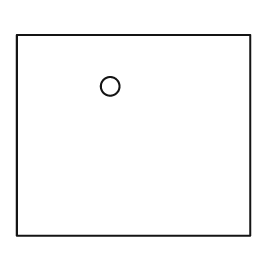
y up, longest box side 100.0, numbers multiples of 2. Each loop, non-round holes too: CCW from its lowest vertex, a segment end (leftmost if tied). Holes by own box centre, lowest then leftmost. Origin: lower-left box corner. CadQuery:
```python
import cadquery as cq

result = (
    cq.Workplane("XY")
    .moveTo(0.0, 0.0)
    .lineTo(100.0, 0.0)
    .lineTo(100.0, 86.0)
    .lineTo(0.0, 86.0)
    .close()
    .moveTo(40.0, 64.0)
    .circle(4.0)
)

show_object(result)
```